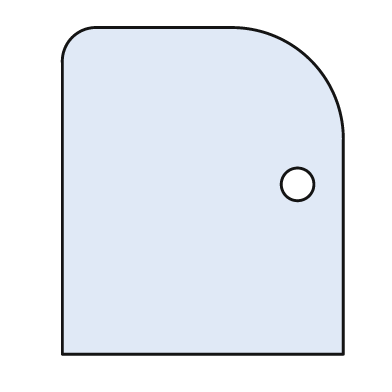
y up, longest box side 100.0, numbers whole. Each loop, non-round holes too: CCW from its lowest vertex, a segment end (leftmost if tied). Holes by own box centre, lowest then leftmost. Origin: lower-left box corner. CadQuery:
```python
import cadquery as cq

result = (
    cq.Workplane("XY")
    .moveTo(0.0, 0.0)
    .lineTo(86.0, 0.0)
    .lineTo(86.0, 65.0)
    .threePointArc((76.0, 90.0), (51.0, 100.0))
    .lineTo(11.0, 100.0)
    .threePointArc((3.0, 97.0), (0.0, 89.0))
    .close()
    .moveTo(72.0, 52.0)
    .circle(5.0)
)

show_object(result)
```